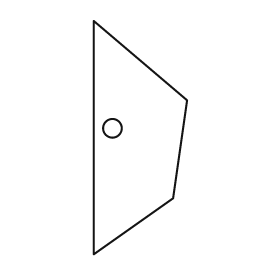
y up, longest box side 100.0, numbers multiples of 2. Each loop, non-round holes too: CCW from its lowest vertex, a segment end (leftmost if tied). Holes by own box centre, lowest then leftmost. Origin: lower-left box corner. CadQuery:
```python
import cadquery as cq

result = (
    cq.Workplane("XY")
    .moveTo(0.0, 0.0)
    .lineTo(34.0, 24.0)
    .lineTo(40.0, 66.0)
    .lineTo(0.0, 100.0)
    .close()
    .moveTo(8.0, 54.0)
    .circle(4.0)
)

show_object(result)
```